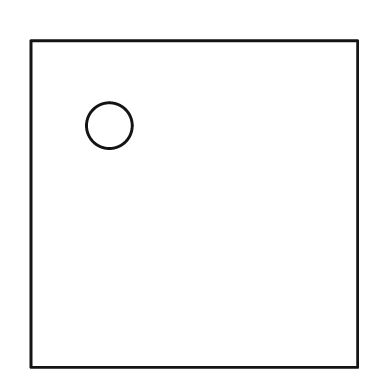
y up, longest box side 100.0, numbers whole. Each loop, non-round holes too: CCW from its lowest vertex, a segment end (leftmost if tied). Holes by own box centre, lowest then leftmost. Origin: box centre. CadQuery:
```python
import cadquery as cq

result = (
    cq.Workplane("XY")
    .moveTo(-50.0, -50.0)
    .lineTo(50.0, -50.0)
    .lineTo(50.0, 50.0)
    .lineTo(-50.0, 50.0)
    .close()
    .moveTo(-26.0, 24.0)
    .circle(7.0)
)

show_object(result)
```